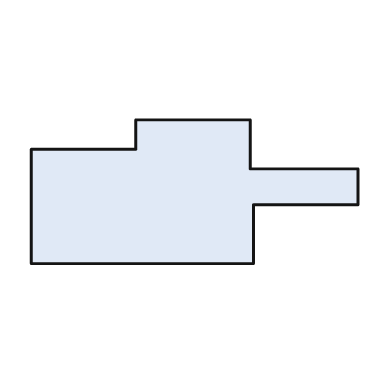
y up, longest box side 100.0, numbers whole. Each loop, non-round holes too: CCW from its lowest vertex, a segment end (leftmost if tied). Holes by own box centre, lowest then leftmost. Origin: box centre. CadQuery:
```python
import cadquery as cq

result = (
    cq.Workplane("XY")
    .moveTo(-50.0, -22.0)
    .lineTo(18.0, -22.0)
    .lineTo(18.0, -4.0)
    .lineTo(50.0, -4.0)
    .lineTo(50.0, 7.0)
    .lineTo(17.0, 7.0)
    .lineTo(17.0, 22.0)
    .lineTo(-18.0, 22.0)
    .lineTo(-18.0, 13.0)
    .lineTo(-50.0, 13.0)
    .close()
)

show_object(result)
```